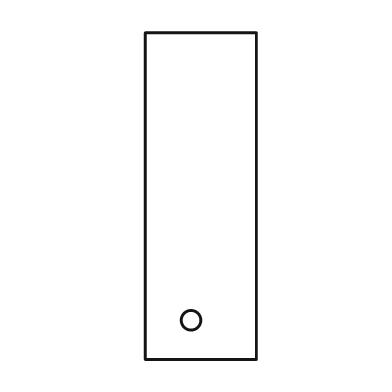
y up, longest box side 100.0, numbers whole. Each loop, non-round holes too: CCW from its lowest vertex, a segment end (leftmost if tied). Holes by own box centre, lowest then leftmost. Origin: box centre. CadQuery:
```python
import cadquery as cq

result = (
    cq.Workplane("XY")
    .moveTo(-17.0, -50.0)
    .lineTo(17.0, -50.0)
    .lineTo(17.0, 50.0)
    .lineTo(-17.0, 50.0)
    .close()
    .moveTo(-3.0, -38.0)
    .circle(3.0)
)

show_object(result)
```